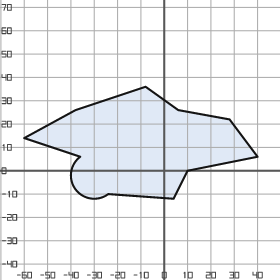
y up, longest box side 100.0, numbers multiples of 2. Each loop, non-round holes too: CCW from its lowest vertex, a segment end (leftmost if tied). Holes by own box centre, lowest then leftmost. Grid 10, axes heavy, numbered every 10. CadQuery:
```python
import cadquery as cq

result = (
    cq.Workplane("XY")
    .moveTo(4.0, -12.0)
    .lineTo(10.0, 0.0)
    .lineTo(40.0, 6.0)
    .lineTo(28.0, 22.0)
    .lineTo(6.0, 26.0)
    .lineTo(-8.0, 36.0)
    .lineTo(-38.0, 26.0)
    .lineTo(-60.0, 14.0)
    .lineTo(-36.0, 6.0)
    .threePointArc((-38.0, -8.0), (-24.0, -10.0))
    .close()
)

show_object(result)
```